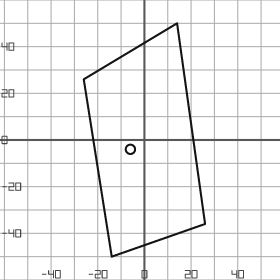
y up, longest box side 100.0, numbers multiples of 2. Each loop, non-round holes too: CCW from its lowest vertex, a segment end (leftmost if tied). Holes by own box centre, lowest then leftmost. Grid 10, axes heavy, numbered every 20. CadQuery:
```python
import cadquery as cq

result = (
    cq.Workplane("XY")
    .moveTo(-14.0, -50.0)
    .lineTo(26.0, -36.0)
    .lineTo(14.0, 50.0)
    .lineTo(-26.0, 26.0)
    .close()
    .moveTo(-6.0, -4.0)
    .circle(2.0)
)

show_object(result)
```